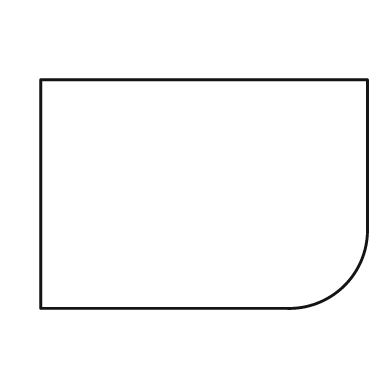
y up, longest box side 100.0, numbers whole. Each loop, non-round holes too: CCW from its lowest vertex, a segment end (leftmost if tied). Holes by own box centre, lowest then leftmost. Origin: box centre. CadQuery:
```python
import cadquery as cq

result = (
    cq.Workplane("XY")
    .moveTo(-50.0, -35.0)
    .lineTo(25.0, -35.0)
    .threePointArc((43.0, -28.0), (50.0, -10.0))
    .lineTo(50.0, 35.0)
    .lineTo(-50.0, 35.0)
    .close()
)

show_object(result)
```